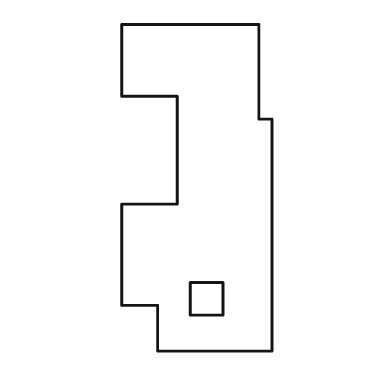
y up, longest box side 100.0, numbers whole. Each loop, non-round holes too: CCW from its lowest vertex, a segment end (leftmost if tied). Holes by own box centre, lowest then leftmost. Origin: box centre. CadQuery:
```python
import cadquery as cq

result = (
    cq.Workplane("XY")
    .moveTo(-12.0, -50.0)
    .lineTo(23.0, -50.0)
    .lineTo(23.0, 21.0)
    .lineTo(19.0, 21.0)
    .lineTo(19.0, 50.0)
    .lineTo(-23.0, 50.0)
    .lineTo(-23.0, 28.0)
    .lineTo(-6.0, 28.0)
    .lineTo(-6.0, -5.0)
    .lineTo(-23.0, -5.0)
    .lineTo(-23.0, -36.0)
    .lineTo(-12.0, -36.0)
    .close()
    .moveTo(-2.0, -39.0)
    .lineTo(8.0, -39.0)
    .lineTo(8.0, -29.0)
    .lineTo(-2.0, -29.0)
    .close()
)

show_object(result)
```